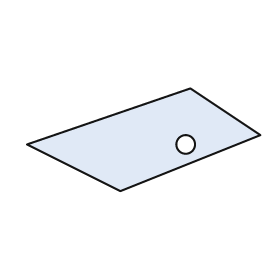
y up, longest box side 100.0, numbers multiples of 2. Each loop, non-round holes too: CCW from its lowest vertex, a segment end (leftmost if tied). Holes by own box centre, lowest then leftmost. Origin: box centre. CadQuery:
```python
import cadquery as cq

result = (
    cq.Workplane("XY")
    .moveTo(-10.0, -22.0)
    .lineTo(50.0, 2.0)
    .lineTo(20.0, 22.0)
    .lineTo(-50.0, -2.0)
    .close()
    .moveTo(18.0, -2.0)
    .circle(4.0)
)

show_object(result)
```